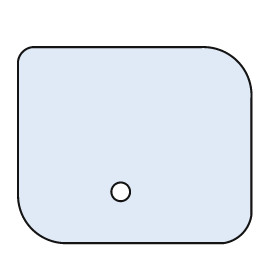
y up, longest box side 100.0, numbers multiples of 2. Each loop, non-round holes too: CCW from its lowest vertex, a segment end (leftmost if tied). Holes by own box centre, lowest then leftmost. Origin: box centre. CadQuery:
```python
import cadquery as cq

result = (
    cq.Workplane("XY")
    .moveTo(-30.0, -42.0)
    .lineTo(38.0, -42.0)
    .threePointArc((46.0, -38.0), (50.0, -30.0))
    .lineTo(50.0, 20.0)
    .threePointArc((44.0, 36.0), (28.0, 42.0))
    .lineTo(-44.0, 42.0)
    .threePointArc((-48.0, 40.0), (-50.0, 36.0))
    .lineTo(-50.0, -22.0)
    .threePointArc((-44.0, -36.0), (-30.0, -42.0))
    .close()
    .moveTo(-6.0, -20.0)
    .circle(4.0)
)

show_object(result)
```